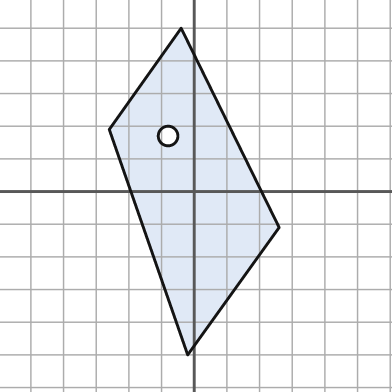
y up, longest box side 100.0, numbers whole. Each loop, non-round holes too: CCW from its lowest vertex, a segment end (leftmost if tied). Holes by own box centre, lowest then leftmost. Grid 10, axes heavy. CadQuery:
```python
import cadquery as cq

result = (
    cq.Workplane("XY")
    .moveTo(-2.0, -50.0)
    .lineTo(26.0, -11.0)
    .lineTo(-4.0, 50.0)
    .lineTo(-26.0, 19.0)
    .close()
    .moveTo(-8.0, 17.0)
    .circle(3.0)
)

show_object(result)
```